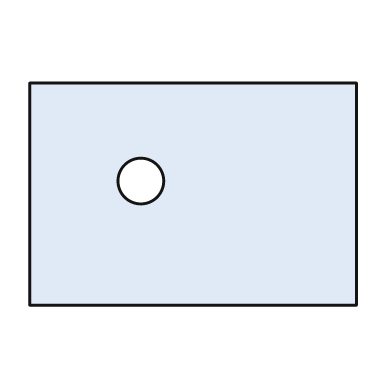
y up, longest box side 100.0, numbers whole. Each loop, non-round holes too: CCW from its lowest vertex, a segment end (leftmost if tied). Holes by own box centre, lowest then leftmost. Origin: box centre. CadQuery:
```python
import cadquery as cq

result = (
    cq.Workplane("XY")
    .moveTo(-50.0, -34.0)
    .lineTo(50.0, -34.0)
    .lineTo(50.0, 34.0)
    .lineTo(-50.0, 34.0)
    .close()
    .moveTo(-16.0, 4.0)
    .circle(7.0)
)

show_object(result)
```